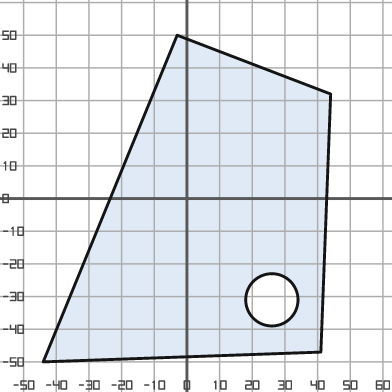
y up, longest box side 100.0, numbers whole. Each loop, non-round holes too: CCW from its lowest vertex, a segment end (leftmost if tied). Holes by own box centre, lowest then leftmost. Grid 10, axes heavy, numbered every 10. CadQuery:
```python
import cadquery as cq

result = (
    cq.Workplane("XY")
    .moveTo(-44.0, -50.0)
    .lineTo(41.0, -47.0)
    .lineTo(44.0, 32.0)
    .lineTo(-3.0, 50.0)
    .close()
    .moveTo(26.0, -31.0)
    .circle(8.0)
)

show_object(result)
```